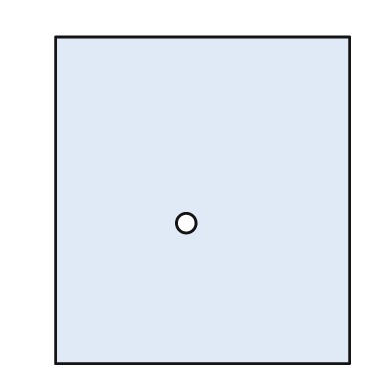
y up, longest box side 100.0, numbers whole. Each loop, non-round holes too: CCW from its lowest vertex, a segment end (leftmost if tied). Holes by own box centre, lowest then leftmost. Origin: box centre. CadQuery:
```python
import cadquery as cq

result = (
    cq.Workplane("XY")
    .moveTo(-45.0, -50.0)
    .lineTo(45.0, -50.0)
    .lineTo(45.0, 50.0)
    .lineTo(-45.0, 50.0)
    .close()
    .moveTo(-5.0, -7.0)
    .circle(3.0)
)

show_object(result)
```